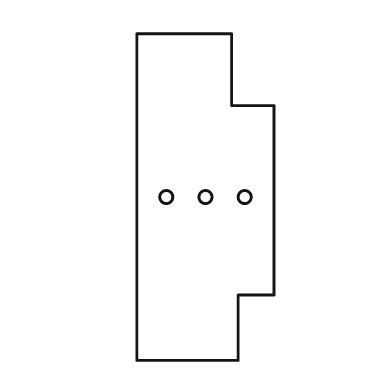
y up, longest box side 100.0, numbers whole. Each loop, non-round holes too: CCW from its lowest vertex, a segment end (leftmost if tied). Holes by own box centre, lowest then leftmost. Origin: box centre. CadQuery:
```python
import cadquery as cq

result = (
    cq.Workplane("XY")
    .moveTo(-21.0, -50.0)
    .lineTo(10.0, -50.0)
    .lineTo(10.0, -30.0)
    .lineTo(21.0, -30.0)
    .lineTo(21.0, 28.0)
    .lineTo(8.0, 28.0)
    .lineTo(8.0, 50.0)
    .lineTo(-21.0, 50.0)
    .close()
    .moveTo(-12.0, 0.0)
    .circle(2.0)
    .moveTo(0.0, 0.0)
    .circle(2.0)
    .moveTo(12.0, 0.0)
    .circle(2.0)
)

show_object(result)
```